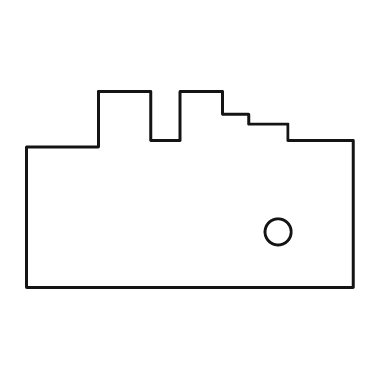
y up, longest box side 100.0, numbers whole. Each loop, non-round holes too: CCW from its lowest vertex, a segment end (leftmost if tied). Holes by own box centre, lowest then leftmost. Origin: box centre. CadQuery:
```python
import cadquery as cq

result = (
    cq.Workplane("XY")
    .moveTo(-50.0, -30.0)
    .lineTo(50.0, -30.0)
    .lineTo(50.0, 15.0)
    .lineTo(30.0, 15.0)
    .lineTo(30.0, 20.0)
    .lineTo(18.0, 20.0)
    .lineTo(18.0, 23.0)
    .lineTo(10.0, 23.0)
    .lineTo(10.0, 30.0)
    .lineTo(-3.0, 30.0)
    .lineTo(-3.0, 15.0)
    .lineTo(-12.0, 15.0)
    .lineTo(-12.0, 30.0)
    .lineTo(-28.0, 30.0)
    .lineTo(-28.0, 13.0)
    .lineTo(-50.0, 13.0)
    .close()
    .moveTo(27.0, -13.0)
    .circle(4.0)
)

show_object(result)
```